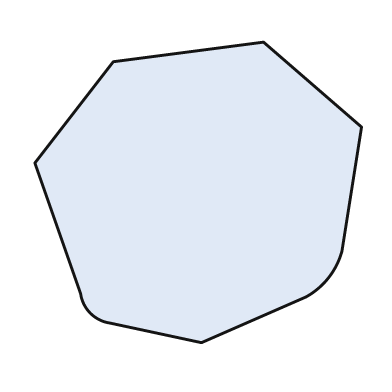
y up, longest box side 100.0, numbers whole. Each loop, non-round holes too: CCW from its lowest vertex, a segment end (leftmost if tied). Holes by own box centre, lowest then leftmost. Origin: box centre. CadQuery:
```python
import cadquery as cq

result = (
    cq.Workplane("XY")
    .moveTo(1.0, -46.0)
    .lineTo(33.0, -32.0)
    .threePointArc((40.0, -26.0), (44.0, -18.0))
    .lineTo(50.0, 20.0)
    .lineTo(20.0, 46.0)
    .lineTo(-26.0, 40.0)
    .lineTo(-50.0, 9.0)
    .lineTo(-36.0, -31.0)
    .threePointArc((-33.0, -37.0), (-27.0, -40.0))
    .close()
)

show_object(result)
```